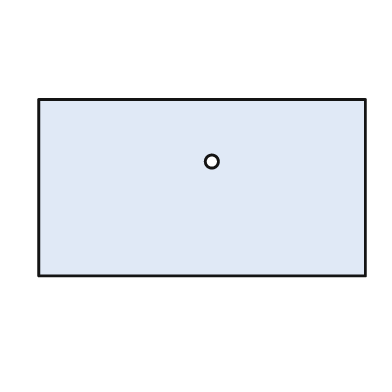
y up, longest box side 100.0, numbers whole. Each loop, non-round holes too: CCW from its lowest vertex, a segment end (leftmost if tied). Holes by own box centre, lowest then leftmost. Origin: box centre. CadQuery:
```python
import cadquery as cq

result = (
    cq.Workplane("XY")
    .moveTo(-50.0, -27.0)
    .lineTo(50.0, -27.0)
    .lineTo(50.0, 27.0)
    .lineTo(-50.0, 27.0)
    .close()
    .moveTo(3.0, 8.0)
    .circle(2.0)
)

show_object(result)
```